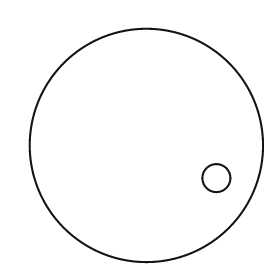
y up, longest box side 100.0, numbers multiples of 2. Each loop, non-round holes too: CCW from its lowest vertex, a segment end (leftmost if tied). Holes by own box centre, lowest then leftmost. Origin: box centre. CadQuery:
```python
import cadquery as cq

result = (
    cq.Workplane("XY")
    .moveTo(0.0, 0.0)
    .circle(50.0)
    .moveTo(30.0, -14.0)
    .circle(6.0)
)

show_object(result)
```